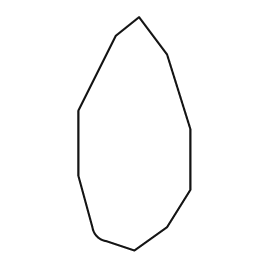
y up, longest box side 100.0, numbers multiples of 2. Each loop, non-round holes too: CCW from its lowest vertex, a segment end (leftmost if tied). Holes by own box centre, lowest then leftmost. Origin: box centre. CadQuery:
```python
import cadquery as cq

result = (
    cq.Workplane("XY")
    .moveTo(0.0, -50.0)
    .lineTo(14.0, -40.0)
    .lineTo(24.0, -24.0)
    .lineTo(24.0, 2.0)
    .lineTo(14.0, 34.0)
    .lineTo(2.0, 50.0)
    .lineTo(-8.0, 42.0)
    .lineTo(-24.0, 10.0)
    .lineTo(-24.0, -18.0)
    .lineTo(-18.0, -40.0)
    .threePointArc((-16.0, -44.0), (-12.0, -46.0))
    .close()
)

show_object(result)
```